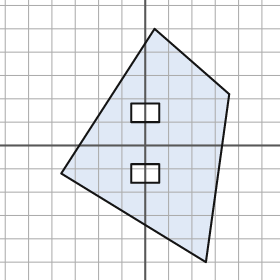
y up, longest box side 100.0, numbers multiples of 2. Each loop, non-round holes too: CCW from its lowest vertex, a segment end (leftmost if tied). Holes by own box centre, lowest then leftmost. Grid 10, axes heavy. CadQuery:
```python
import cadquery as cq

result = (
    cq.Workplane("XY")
    .moveTo(26.0, -50.0)
    .lineTo(36.0, 22.0)
    .lineTo(4.0, 50.0)
    .lineTo(-36.0, -12.0)
    .close()
    .moveTo(-6.0, -16.0)
    .lineTo(6.0, -16.0)
    .lineTo(6.0, -8.0)
    .lineTo(-6.0, -8.0)
    .close()
    .moveTo(-6.0, 10.0)
    .lineTo(6.0, 10.0)
    .lineTo(6.0, 18.0)
    .lineTo(-6.0, 18.0)
    .close()
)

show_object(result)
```